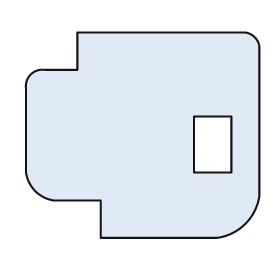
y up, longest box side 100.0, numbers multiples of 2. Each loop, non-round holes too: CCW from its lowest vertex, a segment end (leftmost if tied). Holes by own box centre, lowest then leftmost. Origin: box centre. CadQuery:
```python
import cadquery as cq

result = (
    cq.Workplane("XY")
    .moveTo(-18.0, -44.0)
    .lineTo(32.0, -44.0)
    .threePointArc((44.0, -38.0), (50.0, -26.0))
    .lineTo(50.0, 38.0)
    .threePointArc((48.0, 42.0), (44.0, 44.0))
    .lineTo(-28.0, 44.0)
    .lineTo(-28.0, 28.0)
    .lineTo(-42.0, 28.0)
    .threePointArc((-48.0, 26.0), (-50.0, 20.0))
    .lineTo(-50.0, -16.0)
    .threePointArc((-46.0, -24.0), (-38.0, -28.0))
    .lineTo(-18.0, -28.0)
    .close()
    .moveTo(22.0, -16.0)
    .lineTo(38.0, -16.0)
    .lineTo(38.0, 8.0)
    .lineTo(22.0, 8.0)
    .close()
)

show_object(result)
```